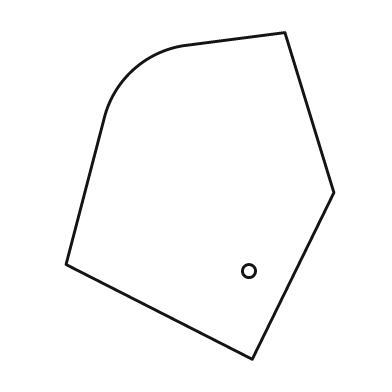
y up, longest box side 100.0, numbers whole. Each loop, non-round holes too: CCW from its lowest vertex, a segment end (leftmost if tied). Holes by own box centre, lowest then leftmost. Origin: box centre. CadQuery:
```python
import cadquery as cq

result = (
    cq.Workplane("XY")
    .moveTo(16.0, -50.0)
    .lineTo(41.0, 1.0)
    .lineTo(26.0, 50.0)
    .lineTo(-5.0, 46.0)
    .threePointArc((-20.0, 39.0), (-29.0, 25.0))
    .lineTo(-41.0, -21.0)
    .close()
    .moveTo(15.0, -23.0)
    .circle(2.0)
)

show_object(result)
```